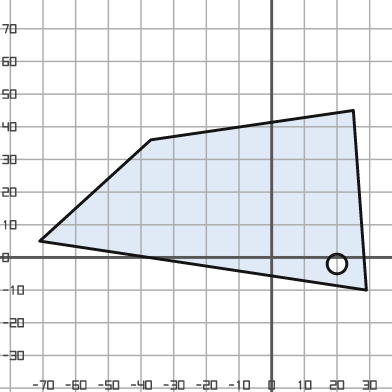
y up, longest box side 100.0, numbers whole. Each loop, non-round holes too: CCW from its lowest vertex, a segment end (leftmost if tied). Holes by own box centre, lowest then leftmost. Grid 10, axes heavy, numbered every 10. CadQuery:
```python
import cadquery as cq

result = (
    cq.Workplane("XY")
    .moveTo(29.0, -10.0)
    .lineTo(25.0, 45.0)
    .lineTo(-37.0, 36.0)
    .lineTo(-71.0, 5.0)
    .close()
    .moveTo(20.0, -2.0)
    .circle(3.0)
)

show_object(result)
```